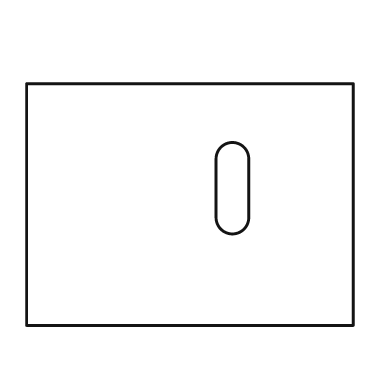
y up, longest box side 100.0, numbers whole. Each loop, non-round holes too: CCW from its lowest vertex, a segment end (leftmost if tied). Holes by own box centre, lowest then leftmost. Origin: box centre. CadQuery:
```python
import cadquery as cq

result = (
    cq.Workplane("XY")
    .moveTo(-50.0, -37.0)
    .lineTo(50.0, -37.0)
    .lineTo(50.0, 37.0)
    .lineTo(-50.0, 37.0)
    .close()
    .moveTo(8.0, -4.0)
    .threePointArc((13.0, -9.0), (18.0, -4.0))
    .lineTo(18.0, 14.0)
    .threePointArc((13.0, 19.0), (8.0, 14.0))
    .close()
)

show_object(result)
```